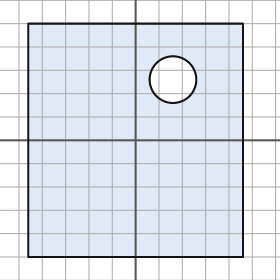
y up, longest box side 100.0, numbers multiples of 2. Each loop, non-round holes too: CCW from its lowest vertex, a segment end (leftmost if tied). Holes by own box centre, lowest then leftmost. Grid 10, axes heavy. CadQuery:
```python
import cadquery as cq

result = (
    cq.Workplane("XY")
    .moveTo(-46.0, -50.0)
    .lineTo(46.0, -50.0)
    .lineTo(46.0, 50.0)
    .lineTo(-46.0, 50.0)
    .close()
    .moveTo(16.0, 26.0)
    .circle(10.0)
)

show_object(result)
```